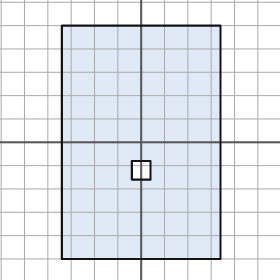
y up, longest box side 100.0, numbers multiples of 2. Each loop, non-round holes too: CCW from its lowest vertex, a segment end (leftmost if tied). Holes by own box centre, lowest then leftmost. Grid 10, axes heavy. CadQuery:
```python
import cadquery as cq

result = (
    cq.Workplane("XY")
    .moveTo(-34.0, -50.0)
    .lineTo(34.0, -50.0)
    .lineTo(34.0, 50.0)
    .lineTo(-34.0, 50.0)
    .close()
    .moveTo(-4.0, -16.0)
    .lineTo(4.0, -16.0)
    .lineTo(4.0, -8.0)
    .lineTo(-4.0, -8.0)
    .close()
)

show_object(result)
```